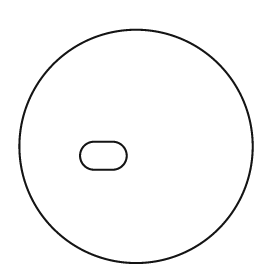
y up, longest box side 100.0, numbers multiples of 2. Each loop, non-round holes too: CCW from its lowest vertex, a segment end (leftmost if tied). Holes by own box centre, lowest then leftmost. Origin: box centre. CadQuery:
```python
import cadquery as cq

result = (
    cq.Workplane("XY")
    .moveTo(0.0, 0.0)
    .circle(50.0)
    .moveTo(-18.0, -10.0)
    .lineTo(-10.0, -10.0)
    .threePointArc((-4.0, -4.0), (-10.0, 2.0))
    .lineTo(-18.0, 2.0)
    .threePointArc((-24.0, -4.0), (-18.0, -10.0))
    .close()
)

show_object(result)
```